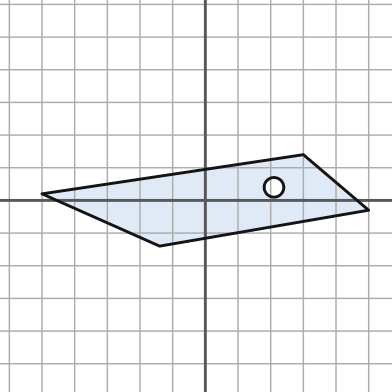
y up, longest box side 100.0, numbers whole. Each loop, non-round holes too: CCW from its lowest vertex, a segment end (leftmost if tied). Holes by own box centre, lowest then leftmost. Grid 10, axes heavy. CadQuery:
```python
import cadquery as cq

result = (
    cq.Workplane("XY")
    .moveTo(-14.0, -14.0)
    .lineTo(50.0, -3.0)
    .lineTo(30.0, 14.0)
    .lineTo(-50.0, 2.0)
    .close()
    .moveTo(21.0, 4.0)
    .circle(3.0)
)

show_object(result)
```